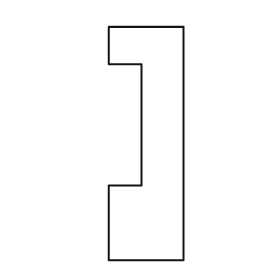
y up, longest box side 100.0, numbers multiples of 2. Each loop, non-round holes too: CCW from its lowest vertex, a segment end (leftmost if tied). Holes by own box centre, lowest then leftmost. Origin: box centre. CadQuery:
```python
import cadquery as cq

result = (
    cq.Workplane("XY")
    .moveTo(-16.0, -50.0)
    .lineTo(16.0, -50.0)
    .lineTo(16.0, 50.0)
    .lineTo(-16.0, 50.0)
    .lineTo(-16.0, 34.0)
    .lineTo(-2.0, 34.0)
    .lineTo(-2.0, -18.0)
    .lineTo(-16.0, -18.0)
    .close()
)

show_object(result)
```